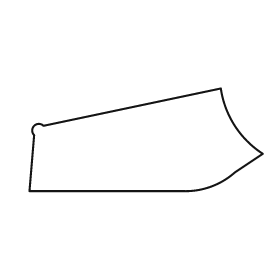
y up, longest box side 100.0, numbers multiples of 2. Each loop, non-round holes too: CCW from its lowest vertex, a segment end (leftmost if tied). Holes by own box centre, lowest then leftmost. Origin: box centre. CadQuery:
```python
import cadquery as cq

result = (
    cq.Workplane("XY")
    .moveTo(-50.0, -22.0)
    .lineTo(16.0, -22.0)
    .threePointArc((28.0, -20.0), (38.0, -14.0))
    .lineTo(50.0, -6.0)
    .threePointArc((38.0, 6.0), (32.0, 22.0))
    .lineTo(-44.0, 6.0)
    .threePointArc((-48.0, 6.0), (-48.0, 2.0))
    .close()
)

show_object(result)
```